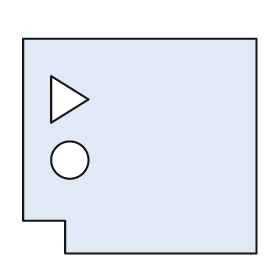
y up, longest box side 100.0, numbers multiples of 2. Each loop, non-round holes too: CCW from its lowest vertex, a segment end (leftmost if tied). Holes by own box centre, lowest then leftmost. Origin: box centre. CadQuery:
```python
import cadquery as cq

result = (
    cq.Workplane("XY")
    .moveTo(-32.0, -46.0)
    .lineTo(50.0, -46.0)
    .lineTo(50.0, 46.0)
    .lineTo(-50.0, 46.0)
    .lineTo(-50.0, -32.0)
    .lineTo(-32.0, -32.0)
    .close()
    .moveTo(-30.0, -6.0)
    .circle(8.0)
    .moveTo(-38.0, 10.0)
    .lineTo(-22.0, 20.0)
    .lineTo(-38.0, 30.0)
    .close()
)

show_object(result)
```